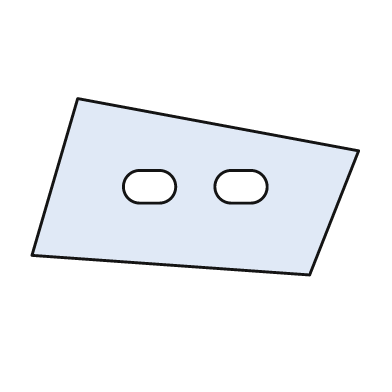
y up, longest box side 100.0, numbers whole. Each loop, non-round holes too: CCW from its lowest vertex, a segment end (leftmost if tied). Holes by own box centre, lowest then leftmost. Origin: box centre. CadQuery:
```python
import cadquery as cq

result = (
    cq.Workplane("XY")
    .moveTo(35.0, -27.0)
    .lineTo(50.0, 11.0)
    .lineTo(-36.0, 27.0)
    .lineTo(-50.0, -21.0)
    .close()
    .moveTo(-17.0, -5.0)
    .lineTo(-11.0, -5.0)
    .threePointArc((-6.0, 0.0), (-11.0, 5.0))
    .lineTo(-17.0, 5.0)
    .threePointArc((-22.0, 0.0), (-17.0, -5.0))
    .close()
    .moveTo(11.0, -5.0)
    .lineTo(17.0, -5.0)
    .threePointArc((22.0, 0.0), (17.0, 5.0))
    .lineTo(11.0, 5.0)
    .threePointArc((6.0, 0.0), (11.0, -5.0))
    .close()
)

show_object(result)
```